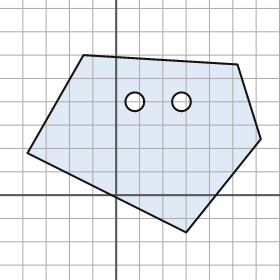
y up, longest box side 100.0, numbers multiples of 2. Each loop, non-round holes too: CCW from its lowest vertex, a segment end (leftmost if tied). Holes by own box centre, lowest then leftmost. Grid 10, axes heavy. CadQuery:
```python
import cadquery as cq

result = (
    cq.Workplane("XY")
    .moveTo(30.0, -16.0)
    .lineTo(62.0, 24.0)
    .lineTo(52.0, 56.0)
    .lineTo(-14.0, 60.0)
    .lineTo(-38.0, 18.0)
    .close()
    .moveTo(8.0, 40.0)
    .circle(4.0)
    .moveTo(28.0, 40.0)
    .circle(4.0)
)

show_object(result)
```